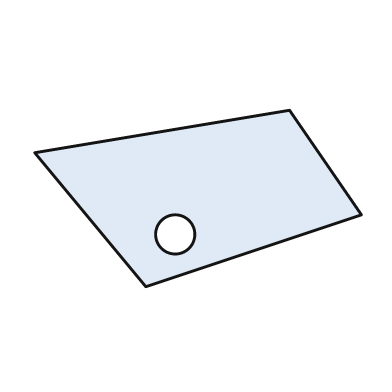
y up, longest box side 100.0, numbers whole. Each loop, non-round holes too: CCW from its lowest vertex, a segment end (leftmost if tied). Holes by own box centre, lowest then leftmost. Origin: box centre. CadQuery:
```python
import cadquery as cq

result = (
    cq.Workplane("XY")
    .moveTo(-16.0, -27.0)
    .lineTo(50.0, -5.0)
    .lineTo(28.0, 27.0)
    .lineTo(-50.0, 14.0)
    .close()
    .moveTo(-7.0, -11.0)
    .circle(6.0)
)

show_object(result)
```